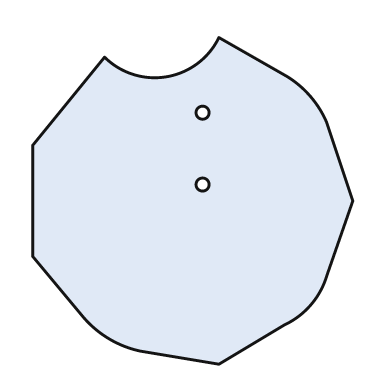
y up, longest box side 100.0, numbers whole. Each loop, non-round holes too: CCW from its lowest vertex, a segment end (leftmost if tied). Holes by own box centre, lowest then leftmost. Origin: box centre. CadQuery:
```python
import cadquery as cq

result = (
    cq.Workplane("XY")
    .moveTo(8.0, -50.0)
    .lineTo(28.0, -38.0)
    .threePointArc((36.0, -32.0), (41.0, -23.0))
    .lineTo(49.0, 0.0)
    .lineTo(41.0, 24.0)
    .threePointArc((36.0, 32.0), (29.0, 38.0))
    .lineTo(8.0, 50.0)
    .threePointArc((-8.0, 38.0), (-27.0, 44.0))
    .lineTo(-49.0, 17.0)
    .lineTo(-49.0, -17.0)
    .lineTo(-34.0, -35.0)
    .threePointArc((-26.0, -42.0), (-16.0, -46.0))
    .close()
    .moveTo(3.0, 5.0)
    .circle(2.0)
    .moveTo(3.0, 27.0)
    .circle(2.0)
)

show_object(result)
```